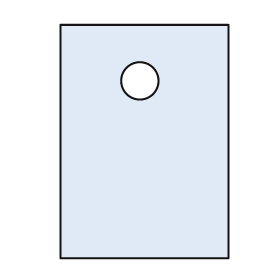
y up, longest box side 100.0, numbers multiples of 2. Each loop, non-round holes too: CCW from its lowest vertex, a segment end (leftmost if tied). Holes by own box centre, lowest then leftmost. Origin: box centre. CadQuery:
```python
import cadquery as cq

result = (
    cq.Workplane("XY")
    .moveTo(-36.0, -50.0)
    .lineTo(36.0, -50.0)
    .lineTo(36.0, 50.0)
    .lineTo(-36.0, 50.0)
    .close()
    .moveTo(-2.0, 26.0)
    .circle(8.0)
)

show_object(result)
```